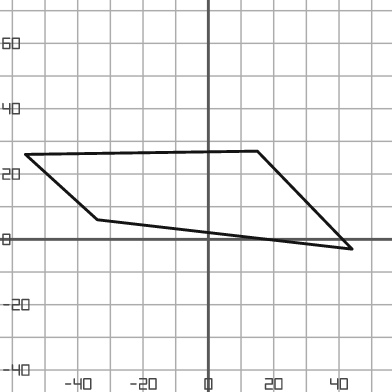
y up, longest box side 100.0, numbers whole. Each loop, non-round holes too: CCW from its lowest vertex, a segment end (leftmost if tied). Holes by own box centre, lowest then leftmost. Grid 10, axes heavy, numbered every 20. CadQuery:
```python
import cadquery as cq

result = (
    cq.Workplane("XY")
    .moveTo(44.0, -3.0)
    .lineTo(15.0, 27.0)
    .lineTo(-56.0, 26.0)
    .lineTo(-34.0, 6.0)
    .close()
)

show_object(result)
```